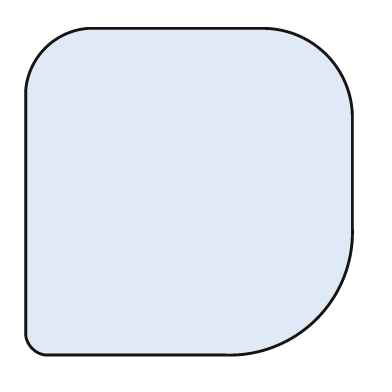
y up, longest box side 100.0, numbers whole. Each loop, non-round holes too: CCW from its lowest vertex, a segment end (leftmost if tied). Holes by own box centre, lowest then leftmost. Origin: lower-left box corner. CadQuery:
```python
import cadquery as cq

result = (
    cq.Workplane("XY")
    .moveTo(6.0, 0.0)
    .lineTo(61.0, 0.0)
    .threePointArc((89.0, 11.0), (100.0, 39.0))
    .lineTo(100.0, 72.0)
    .threePointArc((92.0, 92.0), (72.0, 100.0))
    .lineTo(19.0, 100.0)
    .threePointArc((6.0, 94.0), (0.0, 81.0))
    .lineTo(0.0, 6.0)
    .threePointArc((2.0, 2.0), (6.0, 0.0))
    .close()
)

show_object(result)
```